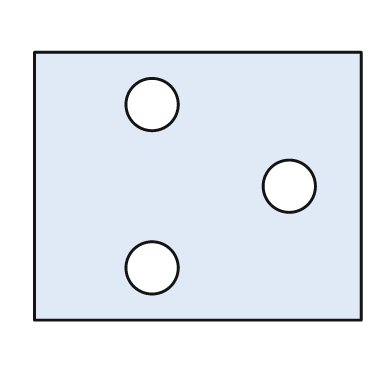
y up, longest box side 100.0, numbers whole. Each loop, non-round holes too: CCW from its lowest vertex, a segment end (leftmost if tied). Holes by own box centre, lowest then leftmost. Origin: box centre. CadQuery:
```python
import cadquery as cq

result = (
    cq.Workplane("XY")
    .moveTo(-50.0, -41.0)
    .lineTo(50.0, -41.0)
    .lineTo(50.0, 41.0)
    .lineTo(-50.0, 41.0)
    .close()
    .moveTo(-14.0, -25.0)
    .circle(8.0)
    .moveTo(28.0, 0.0)
    .circle(8.0)
    .moveTo(-14.0, 25.0)
    .circle(8.0)
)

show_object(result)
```